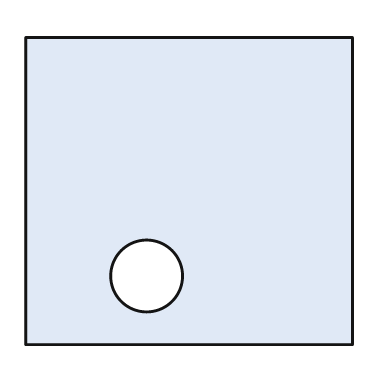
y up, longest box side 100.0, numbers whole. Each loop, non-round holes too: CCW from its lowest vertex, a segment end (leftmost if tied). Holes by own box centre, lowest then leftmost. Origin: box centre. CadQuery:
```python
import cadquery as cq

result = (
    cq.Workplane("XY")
    .moveTo(-50.0, -47.0)
    .lineTo(50.0, -47.0)
    .lineTo(50.0, 47.0)
    .lineTo(-50.0, 47.0)
    .close()
    .moveTo(-13.0, -26.0)
    .circle(11.0)
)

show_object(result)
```